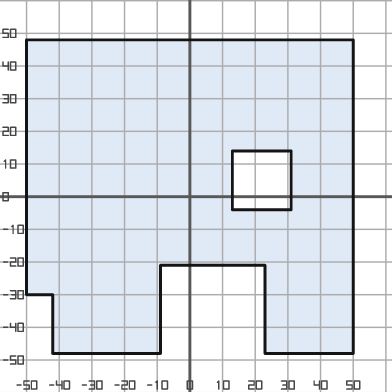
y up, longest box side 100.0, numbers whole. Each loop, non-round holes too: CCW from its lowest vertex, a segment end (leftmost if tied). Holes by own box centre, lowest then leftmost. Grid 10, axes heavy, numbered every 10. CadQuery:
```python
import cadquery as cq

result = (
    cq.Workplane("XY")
    .moveTo(-42.0, -48.0)
    .lineTo(-9.0, -48.0)
    .lineTo(-9.0, -21.0)
    .lineTo(23.0, -21.0)
    .lineTo(23.0, -48.0)
    .lineTo(50.0, -48.0)
    .lineTo(50.0, 48.0)
    .lineTo(-50.0, 48.0)
    .lineTo(-50.0, -30.0)
    .lineTo(-42.0, -30.0)
    .close()
    .moveTo(13.0, -4.0)
    .lineTo(31.0, -4.0)
    .lineTo(31.0, 14.0)
    .lineTo(13.0, 14.0)
    .close()
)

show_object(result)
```